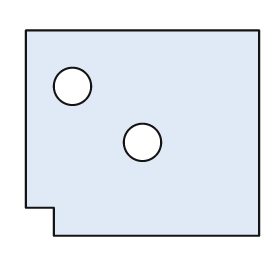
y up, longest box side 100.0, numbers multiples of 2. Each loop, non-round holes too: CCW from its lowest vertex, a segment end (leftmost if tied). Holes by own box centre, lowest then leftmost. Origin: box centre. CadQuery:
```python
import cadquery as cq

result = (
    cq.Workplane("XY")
    .moveTo(-38.0, -44.0)
    .lineTo(50.0, -44.0)
    .lineTo(50.0, 44.0)
    .lineTo(-50.0, 44.0)
    .lineTo(-50.0, -32.0)
    .lineTo(-38.0, -32.0)
    .close()
    .moveTo(0.0, -4.0)
    .circle(8.0)
    .moveTo(-30.0, 20.0)
    .circle(8.0)
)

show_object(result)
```